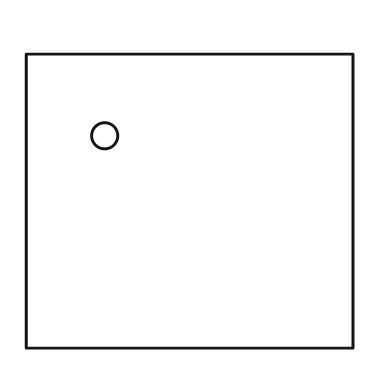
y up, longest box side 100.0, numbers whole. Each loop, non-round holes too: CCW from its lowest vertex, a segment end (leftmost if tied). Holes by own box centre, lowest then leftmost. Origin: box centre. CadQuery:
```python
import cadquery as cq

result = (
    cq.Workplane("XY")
    .moveTo(-50.0, -45.0)
    .lineTo(50.0, -45.0)
    .lineTo(50.0, 45.0)
    .lineTo(-50.0, 45.0)
    .close()
    .moveTo(-26.0, 20.0)
    .circle(4.0)
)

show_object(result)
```